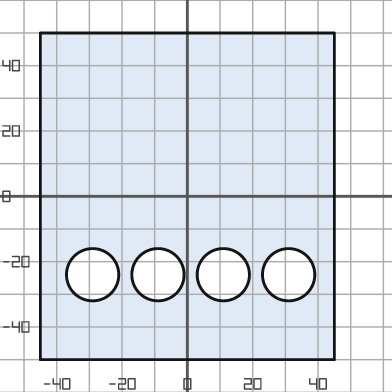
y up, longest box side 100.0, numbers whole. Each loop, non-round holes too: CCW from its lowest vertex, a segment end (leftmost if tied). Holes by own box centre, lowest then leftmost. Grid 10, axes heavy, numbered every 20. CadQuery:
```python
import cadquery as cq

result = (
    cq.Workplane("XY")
    .moveTo(-45.0, -50.0)
    .lineTo(45.0, -50.0)
    .lineTo(45.0, 50.0)
    .lineTo(-45.0, 50.0)
    .close()
    .moveTo(-29.0, -24.0)
    .circle(8.0)
    .moveTo(-9.0, -24.0)
    .circle(8.0)
    .moveTo(11.0, -24.0)
    .circle(8.0)
    .moveTo(31.0, -24.0)
    .circle(8.0)
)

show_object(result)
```